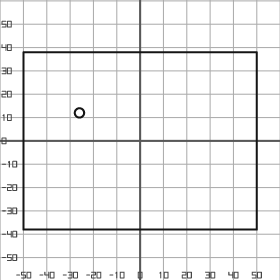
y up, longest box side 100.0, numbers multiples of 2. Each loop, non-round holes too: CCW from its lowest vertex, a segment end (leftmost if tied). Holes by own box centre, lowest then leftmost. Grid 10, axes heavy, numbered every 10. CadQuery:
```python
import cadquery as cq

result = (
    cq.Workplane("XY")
    .moveTo(-50.0, -38.0)
    .lineTo(50.0, -38.0)
    .lineTo(50.0, 38.0)
    .lineTo(-50.0, 38.0)
    .close()
    .moveTo(-26.0, 12.0)
    .circle(2.0)
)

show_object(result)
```